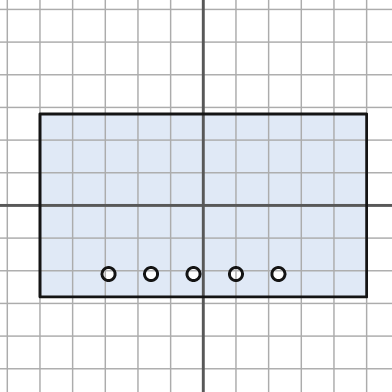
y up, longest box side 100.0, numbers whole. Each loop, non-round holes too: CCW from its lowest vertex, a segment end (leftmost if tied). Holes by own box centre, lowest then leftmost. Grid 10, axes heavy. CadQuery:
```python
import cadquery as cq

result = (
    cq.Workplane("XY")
    .moveTo(-50.0, -28.0)
    .lineTo(50.0, -28.0)
    .lineTo(50.0, 28.0)
    .lineTo(-50.0, 28.0)
    .close()
    .moveTo(-29.0, -21.0)
    .circle(2.0)
    .moveTo(-16.0, -21.0)
    .circle(2.0)
    .moveTo(-3.0, -21.0)
    .circle(2.0)
    .moveTo(10.0, -21.0)
    .circle(2.0)
    .moveTo(23.0, -21.0)
    .circle(2.0)
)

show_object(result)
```